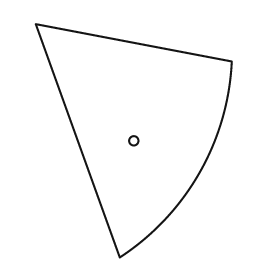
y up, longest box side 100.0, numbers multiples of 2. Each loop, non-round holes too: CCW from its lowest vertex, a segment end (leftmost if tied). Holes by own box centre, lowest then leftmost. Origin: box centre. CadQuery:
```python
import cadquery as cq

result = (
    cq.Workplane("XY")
    .moveTo(-6.0, -50.0)
    .threePointArc((28.0, -14.0), (42.0, 34.0))
    .lineTo(-42.0, 50.0)
    .close()
    .moveTo(0.0, 0.0)
    .circle(2.0)
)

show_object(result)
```